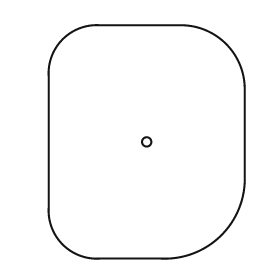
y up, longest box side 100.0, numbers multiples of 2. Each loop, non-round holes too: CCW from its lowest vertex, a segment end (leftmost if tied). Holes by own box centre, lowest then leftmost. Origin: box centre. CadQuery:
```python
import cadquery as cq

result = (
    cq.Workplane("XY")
    .moveTo(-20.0, -50.0)
    .lineTo(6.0, -50.0)
    .threePointArc((32.0, -40.0), (42.0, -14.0))
    .lineTo(42.0, 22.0)
    .threePointArc((34.0, 42.0), (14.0, 50.0))
    .lineTo(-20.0, 50.0)
    .threePointArc((-36.0, 44.0), (-42.0, 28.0))
    .lineTo(-42.0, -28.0)
    .threePointArc((-36.0, -44.0), (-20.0, -50.0))
    .close()
    .moveTo(0.0, 0.0)
    .circle(2.0)
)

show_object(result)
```